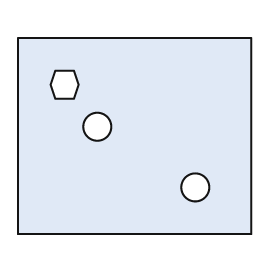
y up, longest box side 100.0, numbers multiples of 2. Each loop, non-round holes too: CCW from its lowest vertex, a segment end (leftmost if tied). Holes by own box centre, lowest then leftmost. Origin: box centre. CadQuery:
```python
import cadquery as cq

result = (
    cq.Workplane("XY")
    .moveTo(-50.0, -42.0)
    .lineTo(50.0, -42.0)
    .lineTo(50.0, 42.0)
    .lineTo(-50.0, 42.0)
    .close()
    .moveTo(26.0, -22.0)
    .circle(6.0)
    .moveTo(-16.0, 4.0)
    .circle(6.0)
    .moveTo(-34.0, 16.0)
    .lineTo(-26.0, 16.0)
    .lineTo(-24.0, 22.0)
    .lineTo(-26.0, 28.0)
    .lineTo(-34.0, 28.0)
    .lineTo(-36.0, 22.0)
    .close()
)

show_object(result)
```